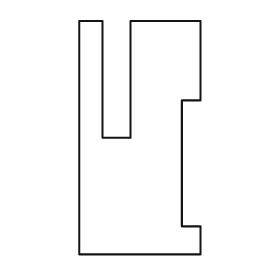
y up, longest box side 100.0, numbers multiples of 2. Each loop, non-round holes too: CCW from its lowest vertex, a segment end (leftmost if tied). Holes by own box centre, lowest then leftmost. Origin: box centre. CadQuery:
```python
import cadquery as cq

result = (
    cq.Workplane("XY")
    .moveTo(-26.0, -50.0)
    .lineTo(26.0, -50.0)
    .lineTo(26.0, -38.0)
    .lineTo(18.0, -38.0)
    .lineTo(18.0, 16.0)
    .lineTo(26.0, 16.0)
    .lineTo(26.0, 50.0)
    .lineTo(-4.0, 50.0)
    .lineTo(-4.0, 0.0)
    .lineTo(-16.0, 0.0)
    .lineTo(-16.0, 50.0)
    .lineTo(-26.0, 50.0)
    .close()
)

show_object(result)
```